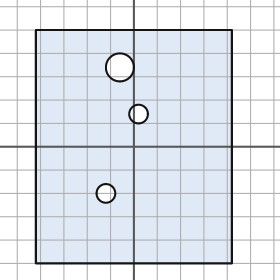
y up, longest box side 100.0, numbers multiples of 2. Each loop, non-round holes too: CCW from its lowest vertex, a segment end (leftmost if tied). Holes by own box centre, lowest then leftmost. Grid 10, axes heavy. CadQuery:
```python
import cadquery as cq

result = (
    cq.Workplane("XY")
    .moveTo(-42.0, -50.0)
    .lineTo(42.0, -50.0)
    .lineTo(42.0, 50.0)
    .lineTo(-42.0, 50.0)
    .close()
    .moveTo(-12.0, -20.0)
    .circle(4.0)
    .moveTo(2.0, 14.0)
    .circle(4.0)
    .moveTo(-6.0, 34.0)
    .circle(6.0)
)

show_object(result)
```